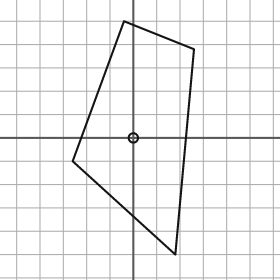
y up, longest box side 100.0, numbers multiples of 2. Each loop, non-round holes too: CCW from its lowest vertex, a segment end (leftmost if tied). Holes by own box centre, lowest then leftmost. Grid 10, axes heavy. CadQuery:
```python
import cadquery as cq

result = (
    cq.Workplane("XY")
    .moveTo(18.0, -50.0)
    .lineTo(26.0, 38.0)
    .lineTo(-4.0, 50.0)
    .lineTo(-26.0, -10.0)
    .close()
    .moveTo(0.0, 0.0)
    .circle(2.0)
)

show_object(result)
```